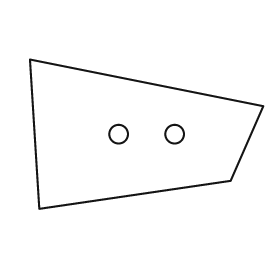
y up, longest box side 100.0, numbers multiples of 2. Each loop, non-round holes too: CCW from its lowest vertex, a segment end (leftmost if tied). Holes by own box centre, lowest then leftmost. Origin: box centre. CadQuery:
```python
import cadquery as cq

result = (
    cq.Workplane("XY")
    .moveTo(-46.0, -32.0)
    .lineTo(36.0, -20.0)
    .lineTo(50.0, 12.0)
    .lineTo(-50.0, 32.0)
    .close()
    .moveTo(-12.0, 0.0)
    .circle(4.0)
    .moveTo(12.0, 0.0)
    .circle(4.0)
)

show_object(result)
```